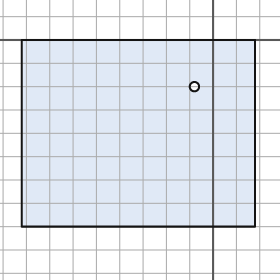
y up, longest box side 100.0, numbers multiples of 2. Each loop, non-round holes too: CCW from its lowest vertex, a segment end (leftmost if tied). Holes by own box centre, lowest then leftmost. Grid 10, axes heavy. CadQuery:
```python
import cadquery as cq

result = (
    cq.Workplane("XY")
    .moveTo(-82.0, -80.0)
    .lineTo(18.0, -80.0)
    .lineTo(18.0, 0.0)
    .lineTo(-82.0, 0.0)
    .close()
    .moveTo(-8.0, -20.0)
    .circle(2.0)
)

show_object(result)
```